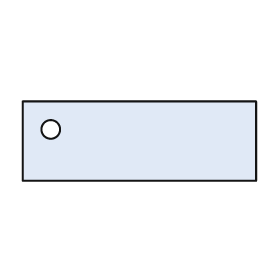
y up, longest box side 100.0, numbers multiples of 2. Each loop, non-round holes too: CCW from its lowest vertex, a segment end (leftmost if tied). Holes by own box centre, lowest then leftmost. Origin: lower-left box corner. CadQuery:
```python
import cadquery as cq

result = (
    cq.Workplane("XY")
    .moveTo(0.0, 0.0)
    .lineTo(100.0, 0.0)
    .lineTo(100.0, 34.0)
    .lineTo(0.0, 34.0)
    .close()
    .moveTo(12.0, 22.0)
    .circle(4.0)
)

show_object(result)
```